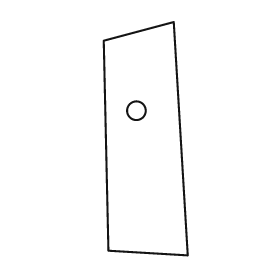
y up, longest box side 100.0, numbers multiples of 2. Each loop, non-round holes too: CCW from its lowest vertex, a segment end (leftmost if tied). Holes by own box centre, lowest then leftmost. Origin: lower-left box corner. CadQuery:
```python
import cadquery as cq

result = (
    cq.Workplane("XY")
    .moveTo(36.0, 0.0)
    .lineTo(30.0, 100.0)
    .lineTo(0.0, 92.0)
    .lineTo(2.0, 2.0)
    .close()
    .moveTo(14.0, 62.0)
    .circle(4.0)
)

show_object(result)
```